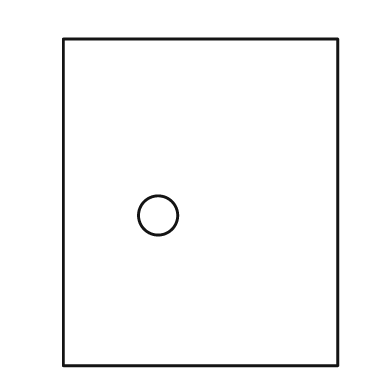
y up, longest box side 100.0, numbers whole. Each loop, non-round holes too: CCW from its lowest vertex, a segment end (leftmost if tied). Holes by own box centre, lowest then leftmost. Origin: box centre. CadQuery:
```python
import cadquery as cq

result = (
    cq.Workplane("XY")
    .moveTo(-42.0, -50.0)
    .lineTo(42.0, -50.0)
    .lineTo(42.0, 50.0)
    .lineTo(-42.0, 50.0)
    .close()
    .moveTo(-13.0, -4.0)
    .circle(6.0)
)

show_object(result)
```